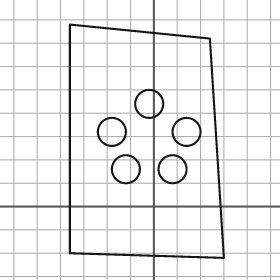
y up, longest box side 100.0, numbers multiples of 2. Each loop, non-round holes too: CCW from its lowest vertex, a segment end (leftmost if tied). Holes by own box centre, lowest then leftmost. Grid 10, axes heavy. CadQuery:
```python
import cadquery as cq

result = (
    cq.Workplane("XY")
    .moveTo(30.0, -22.0)
    .lineTo(24.0, 72.0)
    .lineTo(-36.0, 78.0)
    .lineTo(-36.0, -20.0)
    .close()
    .moveTo(-12.0, 16.0)
    .circle(6.0)
    .moveTo(8.0, 16.0)
    .circle(6.0)
    .moveTo(-18.0, 32.0)
    .circle(6.0)
    .moveTo(14.0, 32.0)
    .circle(6.0)
    .moveTo(-2.0, 44.0)
    .circle(6.0)
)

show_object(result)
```